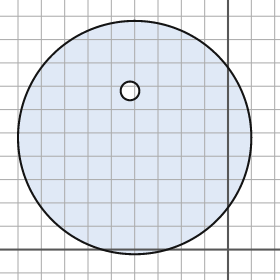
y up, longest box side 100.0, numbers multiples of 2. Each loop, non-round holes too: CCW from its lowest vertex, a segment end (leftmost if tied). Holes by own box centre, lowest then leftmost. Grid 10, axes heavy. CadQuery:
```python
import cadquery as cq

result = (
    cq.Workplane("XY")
    .moveTo(-40.0, 48.0)
    .circle(50.0)
    .moveTo(-42.0, 68.0)
    .circle(4.0)
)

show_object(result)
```